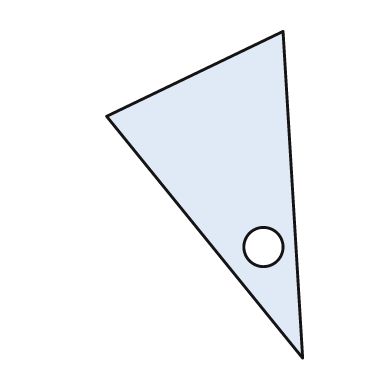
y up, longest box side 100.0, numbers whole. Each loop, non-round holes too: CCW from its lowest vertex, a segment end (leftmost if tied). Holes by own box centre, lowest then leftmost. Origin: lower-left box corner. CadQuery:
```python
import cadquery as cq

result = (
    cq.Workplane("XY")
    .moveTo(60.0, 0.0)
    .lineTo(54.0, 100.0)
    .lineTo(0.0, 74.0)
    .close()
    .moveTo(48.0, 34.0)
    .circle(6.0)
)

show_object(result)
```